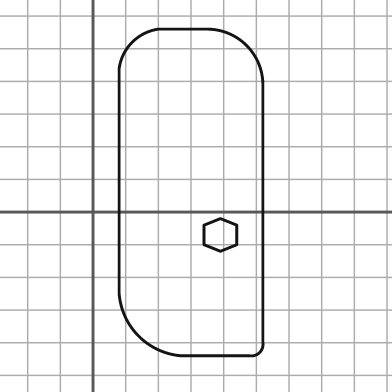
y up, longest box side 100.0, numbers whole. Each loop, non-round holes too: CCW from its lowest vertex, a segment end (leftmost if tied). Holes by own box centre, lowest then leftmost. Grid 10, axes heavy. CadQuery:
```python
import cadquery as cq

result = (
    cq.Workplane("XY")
    .moveTo(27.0, -44.0)
    .lineTo(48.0, -44.0)
    .threePointArc((51.0, -43.0), (52.0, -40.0))
    .lineTo(52.0, 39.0)
    .threePointArc((47.0, 51.0), (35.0, 56.0))
    .lineTo(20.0, 56.0)
    .threePointArc((12.0, 52.0), (8.0, 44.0))
    .lineTo(8.0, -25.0)
    .threePointArc((14.0, -38.0), (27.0, -44.0))
    .close()
    .moveTo(39.0, -12.0)
    .lineTo(44.0, -10.0)
    .lineTo(44.0, -4.0)
    .lineTo(39.0, -2.0)
    .lineTo(34.0, -4.0)
    .lineTo(34.0, -10.0)
    .close()
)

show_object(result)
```